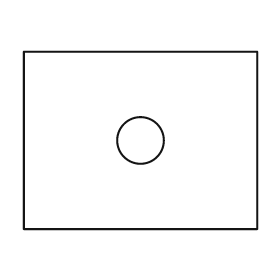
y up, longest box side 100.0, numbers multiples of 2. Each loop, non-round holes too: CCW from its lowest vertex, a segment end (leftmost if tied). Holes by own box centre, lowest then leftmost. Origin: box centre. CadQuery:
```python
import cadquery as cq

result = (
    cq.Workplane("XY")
    .moveTo(-50.0, -38.0)
    .lineTo(50.0, -38.0)
    .lineTo(50.0, 38.0)
    .lineTo(-50.0, 38.0)
    .close()
    .moveTo(0.0, 0.0)
    .circle(10.0)
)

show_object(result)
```